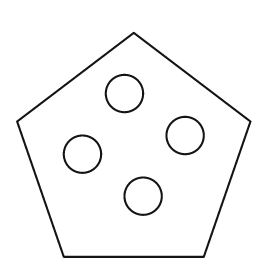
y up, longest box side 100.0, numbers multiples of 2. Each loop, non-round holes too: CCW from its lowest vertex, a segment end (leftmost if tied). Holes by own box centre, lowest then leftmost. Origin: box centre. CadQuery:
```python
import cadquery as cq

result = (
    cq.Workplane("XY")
    .moveTo(-30.0, -48.0)
    .lineTo(30.0, -48.0)
    .lineTo(50.0, 10.0)
    .lineTo(0.0, 48.0)
    .lineTo(-50.0, 10.0)
    .close()
    .moveTo(4.0, -22.0)
    .circle(8.0)
    .moveTo(-22.0, -4.0)
    .circle(8.0)
    .moveTo(22.0, 4.0)
    .circle(8.0)
    .moveTo(-4.0, 22.0)
    .circle(8.0)
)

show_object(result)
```